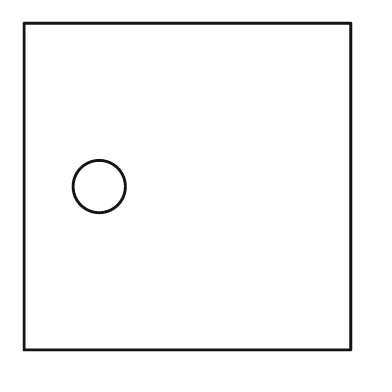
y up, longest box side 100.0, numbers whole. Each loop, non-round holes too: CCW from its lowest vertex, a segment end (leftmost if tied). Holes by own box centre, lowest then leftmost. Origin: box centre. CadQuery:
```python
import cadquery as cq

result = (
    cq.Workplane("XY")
    .moveTo(-50.0, -50.0)
    .lineTo(50.0, -50.0)
    .lineTo(50.0, 50.0)
    .lineTo(-50.0, 50.0)
    .close()
    .moveTo(-27.0, 0.0)
    .circle(8.0)
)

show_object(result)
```